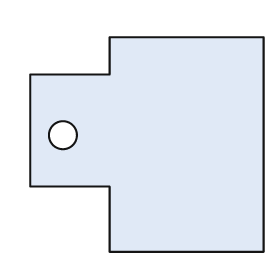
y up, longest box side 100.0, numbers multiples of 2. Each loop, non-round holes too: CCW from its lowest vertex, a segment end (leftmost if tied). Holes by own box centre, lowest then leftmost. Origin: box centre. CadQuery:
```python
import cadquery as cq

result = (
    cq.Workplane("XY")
    .moveTo(-16.0, -46.0)
    .lineTo(50.0, -46.0)
    .lineTo(50.0, 46.0)
    .lineTo(-16.0, 46.0)
    .lineTo(-16.0, 30.0)
    .lineTo(-50.0, 30.0)
    .lineTo(-50.0, -18.0)
    .lineTo(-16.0, -18.0)
    .close()
    .moveTo(-36.0, 4.0)
    .circle(6.0)
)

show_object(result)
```